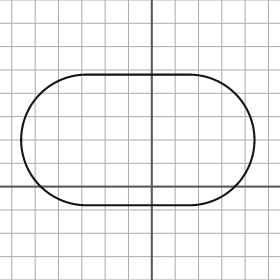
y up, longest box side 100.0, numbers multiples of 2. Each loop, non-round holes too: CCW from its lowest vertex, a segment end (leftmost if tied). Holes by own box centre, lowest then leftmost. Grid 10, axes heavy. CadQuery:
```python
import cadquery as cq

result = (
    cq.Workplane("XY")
    .moveTo(-28.0, -8.0)
    .lineTo(16.0, -8.0)
    .threePointArc((44.0, 20.0), (16.0, 48.0))
    .lineTo(-28.0, 48.0)
    .threePointArc((-56.0, 20.0), (-28.0, -8.0))
    .close()
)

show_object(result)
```